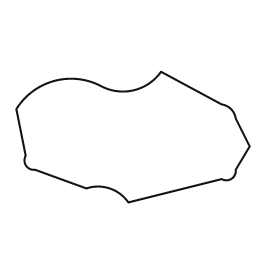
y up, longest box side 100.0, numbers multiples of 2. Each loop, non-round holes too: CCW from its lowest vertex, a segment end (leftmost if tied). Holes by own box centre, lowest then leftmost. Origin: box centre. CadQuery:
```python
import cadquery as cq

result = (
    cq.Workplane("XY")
    .moveTo(-2.0, -28.0)
    .lineTo(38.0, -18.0)
    .threePointArc((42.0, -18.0), (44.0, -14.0))
    .lineTo(50.0, -4.0)
    .lineTo(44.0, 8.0)
    .threePointArc((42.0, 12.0), (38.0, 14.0))
    .lineTo(12.0, 28.0)
    .threePointArc((0.0, 20.0), (-14.0, 22.0))
    .threePointArc((-34.0, 24.0), (-50.0, 12.0))
    .lineTo(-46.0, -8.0)
    .threePointArc((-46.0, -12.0), (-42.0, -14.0))
    .lineTo(-20.0, -22.0)
    .threePointArc((-10.0, -22.0), (-2.0, -28.0))
    .close()
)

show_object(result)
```